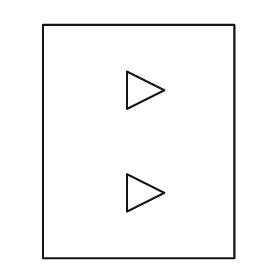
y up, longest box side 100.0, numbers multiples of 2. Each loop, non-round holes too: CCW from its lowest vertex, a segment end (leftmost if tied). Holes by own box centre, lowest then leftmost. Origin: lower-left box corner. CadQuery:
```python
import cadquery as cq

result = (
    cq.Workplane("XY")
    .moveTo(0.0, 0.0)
    .lineTo(82.0, 0.0)
    .lineTo(82.0, 100.0)
    .lineTo(0.0, 100.0)
    .close()
    .moveTo(36.0, 20.0)
    .lineTo(52.0, 28.0)
    .lineTo(36.0, 36.0)
    .close()
    .moveTo(36.0, 64.0)
    .lineTo(52.0, 72.0)
    .lineTo(36.0, 80.0)
    .close()
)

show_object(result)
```